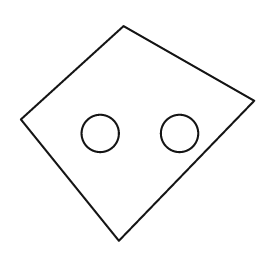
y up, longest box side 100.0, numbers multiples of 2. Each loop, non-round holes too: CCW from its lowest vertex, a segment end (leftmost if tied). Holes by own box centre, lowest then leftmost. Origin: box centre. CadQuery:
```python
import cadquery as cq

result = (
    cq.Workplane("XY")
    .moveTo(-8.0, -46.0)
    .lineTo(50.0, 14.0)
    .lineTo(-6.0, 46.0)
    .lineTo(-50.0, 6.0)
    .close()
    .moveTo(-16.0, 0.0)
    .circle(8.0)
    .moveTo(18.0, 0.0)
    .circle(8.0)
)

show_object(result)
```